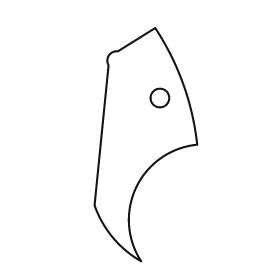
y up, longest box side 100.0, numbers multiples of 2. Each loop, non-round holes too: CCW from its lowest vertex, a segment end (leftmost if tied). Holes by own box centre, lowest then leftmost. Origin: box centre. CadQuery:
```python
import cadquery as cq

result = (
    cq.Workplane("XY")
    .moveTo(-2.0, -50.0)
    .threePointArc((-4.0, -18.0), (22.0, 0.0))
    .threePointArc((16.0, 26.0), (4.0, 50.0))
    .lineTo(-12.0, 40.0)
    .threePointArc((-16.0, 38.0), (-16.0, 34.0))
    .lineTo(-22.0, -26.0)
    .threePointArc((-14.0, -40.0), (-2.0, -50.0))
    .close()
    .moveTo(6.0, 20.0)
    .circle(4.0)
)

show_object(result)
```